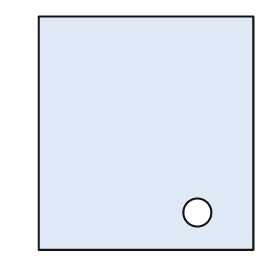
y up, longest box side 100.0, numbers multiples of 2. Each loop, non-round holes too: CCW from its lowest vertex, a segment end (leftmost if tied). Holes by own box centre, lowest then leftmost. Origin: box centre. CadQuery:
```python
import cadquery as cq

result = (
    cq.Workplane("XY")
    .moveTo(-46.0, -50.0)
    .lineTo(46.0, -50.0)
    .lineTo(46.0, 50.0)
    .lineTo(-46.0, 50.0)
    .close()
    .moveTo(22.0, -34.0)
    .circle(6.0)
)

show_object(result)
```